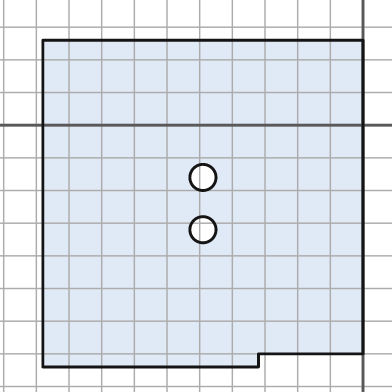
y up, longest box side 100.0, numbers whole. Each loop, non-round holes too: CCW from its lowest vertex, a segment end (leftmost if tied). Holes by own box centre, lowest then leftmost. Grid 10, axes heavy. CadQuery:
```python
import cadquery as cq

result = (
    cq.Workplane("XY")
    .moveTo(-98.0, -74.0)
    .lineTo(-32.0, -74.0)
    .lineTo(-32.0, -70.0)
    .lineTo(0.0, -70.0)
    .lineTo(0.0, 26.0)
    .lineTo(-98.0, 26.0)
    .close()
    .moveTo(-49.0, -32.0)
    .circle(4.0)
    .moveTo(-49.0, -16.0)
    .circle(4.0)
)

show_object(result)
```